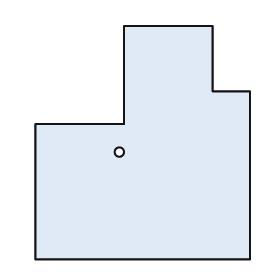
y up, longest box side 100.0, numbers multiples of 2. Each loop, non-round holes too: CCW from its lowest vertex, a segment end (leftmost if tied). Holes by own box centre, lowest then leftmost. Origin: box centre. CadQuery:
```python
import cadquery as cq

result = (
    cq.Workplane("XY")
    .moveTo(-46.0, -50.0)
    .lineTo(46.0, -50.0)
    .lineTo(46.0, 22.0)
    .lineTo(30.0, 22.0)
    .lineTo(30.0, 50.0)
    .lineTo(-8.0, 50.0)
    .lineTo(-8.0, 8.0)
    .lineTo(-46.0, 8.0)
    .close()
    .moveTo(-10.0, -4.0)
    .circle(2.0)
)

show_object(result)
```